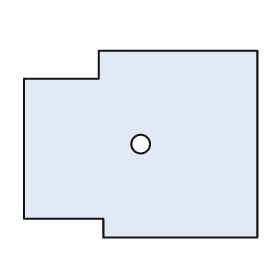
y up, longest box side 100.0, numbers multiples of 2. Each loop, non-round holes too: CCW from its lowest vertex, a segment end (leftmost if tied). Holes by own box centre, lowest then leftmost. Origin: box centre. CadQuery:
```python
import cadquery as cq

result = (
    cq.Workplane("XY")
    .moveTo(-16.0, -40.0)
    .lineTo(50.0, -40.0)
    .lineTo(50.0, 40.0)
    .lineTo(-18.0, 40.0)
    .lineTo(-18.0, 28.0)
    .lineTo(-50.0, 28.0)
    .lineTo(-50.0, -32.0)
    .lineTo(-16.0, -32.0)
    .close()
    .moveTo(0.0, 0.0)
    .circle(4.0)
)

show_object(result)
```